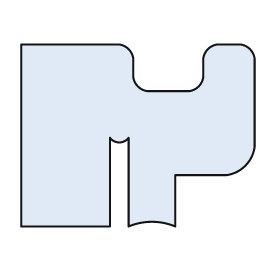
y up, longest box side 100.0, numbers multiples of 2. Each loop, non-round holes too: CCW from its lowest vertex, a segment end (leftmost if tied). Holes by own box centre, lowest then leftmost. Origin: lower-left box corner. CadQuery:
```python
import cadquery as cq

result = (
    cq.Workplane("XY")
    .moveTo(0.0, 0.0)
    .lineTo(38.0, 0.0)
    .lineTo(38.0, 38.0)
    .threePointArc((42.0, 36.0), (46.0, 38.0))
    .lineTo(46.0, 0.0)
    .threePointArc((56.0, 2.0), (66.0, 0.0))
    .lineTo(66.0, 22.0)
    .lineTo(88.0, 22.0)
    .threePointArc((96.0, 26.0), (100.0, 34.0))
    .lineTo(100.0, 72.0)
    .threePointArc((98.0, 76.0), (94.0, 78.0))
    .lineTo(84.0, 78.0)
    .threePointArc((80.0, 76.0), (78.0, 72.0))
    .lineTo(78.0, 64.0)
    .threePointArc((76.0, 60.0), (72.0, 58.0))
    .lineTo(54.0, 58.0)
    .threePointArc((50.0, 60.0), (48.0, 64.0))
    .lineTo(48.0, 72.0)
    .threePointArc((46.0, 76.0), (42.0, 78.0))
    .lineTo(0.0, 78.0)
    .close()
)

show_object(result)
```